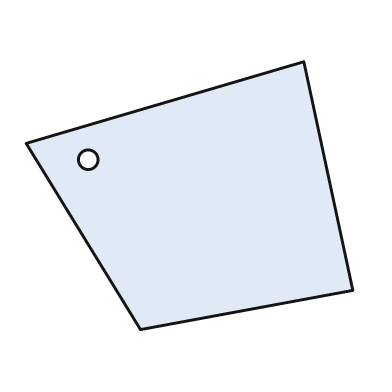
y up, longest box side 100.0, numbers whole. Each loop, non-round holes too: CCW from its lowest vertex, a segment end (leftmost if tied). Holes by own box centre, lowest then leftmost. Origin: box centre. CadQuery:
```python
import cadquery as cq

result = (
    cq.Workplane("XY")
    .moveTo(-15.0, -41.0)
    .lineTo(50.0, -29.0)
    .lineTo(35.0, 41.0)
    .lineTo(-50.0, 16.0)
    .close()
    .moveTo(-31.0, 11.0)
    .circle(3.0)
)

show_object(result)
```